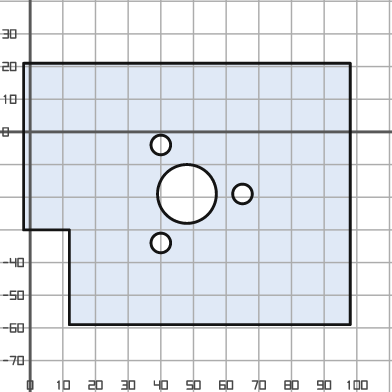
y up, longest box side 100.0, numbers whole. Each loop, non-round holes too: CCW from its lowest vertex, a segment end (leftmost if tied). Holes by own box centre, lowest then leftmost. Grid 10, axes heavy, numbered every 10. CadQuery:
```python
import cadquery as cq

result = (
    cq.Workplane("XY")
    .moveTo(12.0, -59.0)
    .lineTo(98.0, -59.0)
    .lineTo(98.0, 21.0)
    .lineTo(-2.0, 21.0)
    .lineTo(-2.0, -30.0)
    .lineTo(12.0, -30.0)
    .close()
    .moveTo(40.0, -34.0)
    .circle(3.0)
    .moveTo(48.0, -19.0)
    .circle(9.0)
    .moveTo(65.0, -19.0)
    .circle(3.0)
    .moveTo(40.0, -4.0)
    .circle(3.0)
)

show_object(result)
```